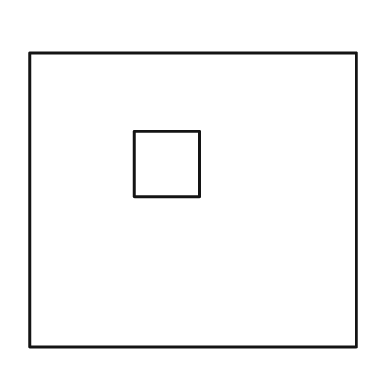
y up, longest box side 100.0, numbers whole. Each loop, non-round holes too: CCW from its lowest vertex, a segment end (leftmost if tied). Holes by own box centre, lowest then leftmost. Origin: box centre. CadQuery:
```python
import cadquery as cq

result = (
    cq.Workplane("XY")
    .moveTo(-50.0, -45.0)
    .lineTo(50.0, -45.0)
    .lineTo(50.0, 45.0)
    .lineTo(-50.0, 45.0)
    .close()
    .moveTo(-18.0, 1.0)
    .lineTo(2.0, 1.0)
    .lineTo(2.0, 21.0)
    .lineTo(-18.0, 21.0)
    .close()
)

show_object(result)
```